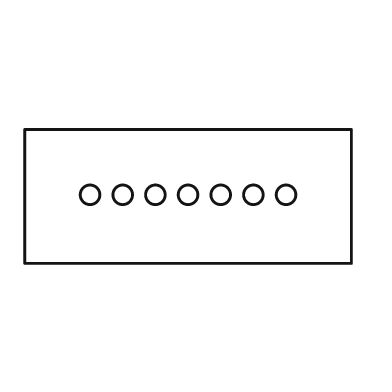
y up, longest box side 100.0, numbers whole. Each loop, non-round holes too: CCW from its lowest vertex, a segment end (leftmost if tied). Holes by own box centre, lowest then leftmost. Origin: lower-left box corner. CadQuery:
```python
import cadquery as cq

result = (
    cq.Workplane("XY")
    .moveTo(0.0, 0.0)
    .lineTo(100.0, 0.0)
    .lineTo(100.0, 41.0)
    .lineTo(0.0, 41.0)
    .close()
    .moveTo(20.0, 21.0)
    .circle(3.0)
    .moveTo(30.0, 21.0)
    .circle(3.0)
    .moveTo(40.0, 21.0)
    .circle(3.0)
    .moveTo(50.0, 21.0)
    .circle(3.0)
    .moveTo(60.0, 21.0)
    .circle(3.0)
    .moveTo(70.0, 21.0)
    .circle(3.0)
    .moveTo(80.0, 21.0)
    .circle(3.0)
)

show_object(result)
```